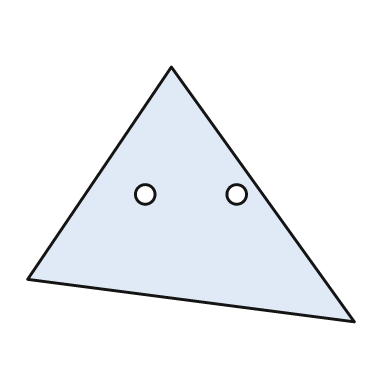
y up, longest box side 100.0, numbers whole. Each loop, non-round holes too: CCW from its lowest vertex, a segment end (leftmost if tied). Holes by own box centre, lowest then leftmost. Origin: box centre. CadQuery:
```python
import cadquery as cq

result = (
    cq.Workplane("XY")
    .moveTo(50.0, -39.0)
    .lineTo(-6.0, 39.0)
    .lineTo(-50.0, -26.0)
    .close()
    .moveTo(-14.0, 0.0)
    .circle(3.0)
    .moveTo(14.0, 0.0)
    .circle(3.0)
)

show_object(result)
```